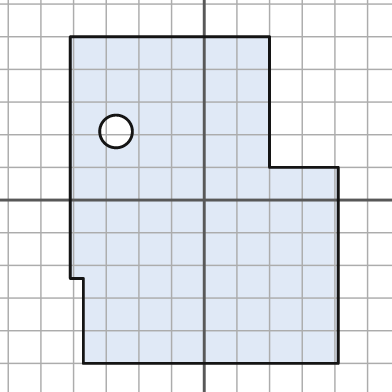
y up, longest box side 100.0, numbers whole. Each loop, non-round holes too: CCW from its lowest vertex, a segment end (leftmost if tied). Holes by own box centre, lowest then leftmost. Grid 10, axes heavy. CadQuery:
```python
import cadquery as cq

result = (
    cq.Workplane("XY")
    .moveTo(-37.0, -50.0)
    .lineTo(41.0, -50.0)
    .lineTo(41.0, 10.0)
    .lineTo(20.0, 10.0)
    .lineTo(20.0, 50.0)
    .lineTo(-41.0, 50.0)
    .lineTo(-41.0, -24.0)
    .lineTo(-37.0, -24.0)
    .close()
    .moveTo(-27.0, 21.0)
    .circle(5.0)
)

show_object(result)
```